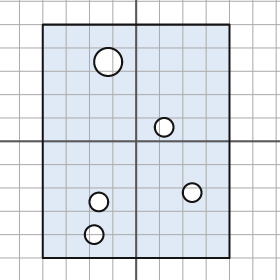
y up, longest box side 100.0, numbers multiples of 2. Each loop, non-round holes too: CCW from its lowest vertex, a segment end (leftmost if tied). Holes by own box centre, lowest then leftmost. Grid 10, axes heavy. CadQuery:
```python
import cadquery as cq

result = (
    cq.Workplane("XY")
    .moveTo(-40.0, -50.0)
    .lineTo(40.0, -50.0)
    .lineTo(40.0, 50.0)
    .lineTo(-40.0, 50.0)
    .close()
    .moveTo(-18.0, -40.0)
    .circle(4.0)
    .moveTo(-16.0, -26.0)
    .circle(4.0)
    .moveTo(24.0, -22.0)
    .circle(4.0)
    .moveTo(12.0, 6.0)
    .circle(4.0)
    .moveTo(-12.0, 34.0)
    .circle(6.0)
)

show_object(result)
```